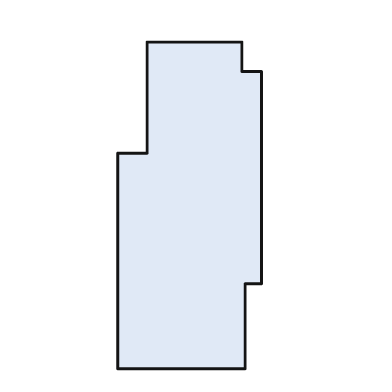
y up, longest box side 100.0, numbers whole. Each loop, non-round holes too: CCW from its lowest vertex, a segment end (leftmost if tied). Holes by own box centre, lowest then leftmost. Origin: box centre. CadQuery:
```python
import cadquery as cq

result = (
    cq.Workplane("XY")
    .moveTo(-22.0, -50.0)
    .lineTo(17.0, -50.0)
    .lineTo(17.0, -24.0)
    .lineTo(22.0, -24.0)
    .lineTo(22.0, 41.0)
    .lineTo(16.0, 41.0)
    .lineTo(16.0, 50.0)
    .lineTo(-13.0, 50.0)
    .lineTo(-13.0, 16.0)
    .lineTo(-22.0, 16.0)
    .close()
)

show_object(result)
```